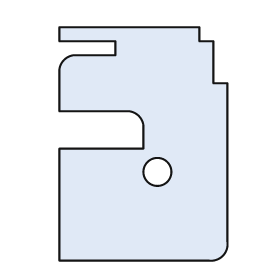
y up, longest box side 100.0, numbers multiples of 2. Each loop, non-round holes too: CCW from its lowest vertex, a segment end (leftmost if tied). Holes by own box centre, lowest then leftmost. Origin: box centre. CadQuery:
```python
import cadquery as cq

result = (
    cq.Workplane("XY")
    .moveTo(-36.0, -50.0)
    .lineTo(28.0, -50.0)
    .threePointArc((34.0, -48.0), (36.0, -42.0))
    .lineTo(36.0, 26.0)
    .lineTo(30.0, 26.0)
    .lineTo(30.0, 44.0)
    .lineTo(24.0, 44.0)
    .lineTo(24.0, 50.0)
    .lineTo(-36.0, 50.0)
    .lineTo(-36.0, 44.0)
    .lineTo(-12.0, 44.0)
    .lineTo(-12.0, 38.0)
    .lineTo(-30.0, 38.0)
    .threePointArc((-34.0, 36.0), (-36.0, 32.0))
    .lineTo(-36.0, 14.0)
    .lineTo(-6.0, 14.0)
    .threePointArc((-2.0, 12.0), (0.0, 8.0))
    .lineTo(0.0, -2.0)
    .lineTo(-36.0, -2.0)
    .close()
    .moveTo(6.0, -12.0)
    .circle(6.0)
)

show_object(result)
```